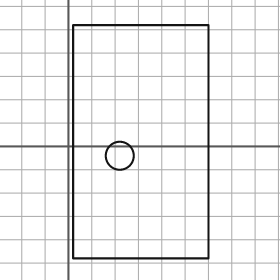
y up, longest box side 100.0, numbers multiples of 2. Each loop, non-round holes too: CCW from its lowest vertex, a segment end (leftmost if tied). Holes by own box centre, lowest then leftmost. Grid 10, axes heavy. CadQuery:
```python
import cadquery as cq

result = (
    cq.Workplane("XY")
    .moveTo(2.0, -48.0)
    .lineTo(60.0, -48.0)
    .lineTo(60.0, 52.0)
    .lineTo(2.0, 52.0)
    .close()
    .moveTo(22.0, -4.0)
    .circle(6.0)
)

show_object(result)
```